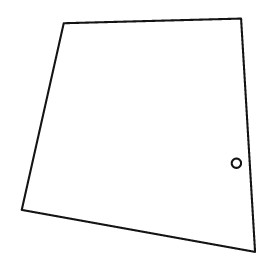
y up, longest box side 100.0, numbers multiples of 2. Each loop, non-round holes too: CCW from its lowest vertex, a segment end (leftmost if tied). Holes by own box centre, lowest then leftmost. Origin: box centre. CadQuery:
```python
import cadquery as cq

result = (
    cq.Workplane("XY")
    .moveTo(50.0, -50.0)
    .lineTo(44.0, 50.0)
    .lineTo(-32.0, 48.0)
    .lineTo(-50.0, -32.0)
    .close()
    .moveTo(42.0, -12.0)
    .circle(2.0)
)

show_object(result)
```